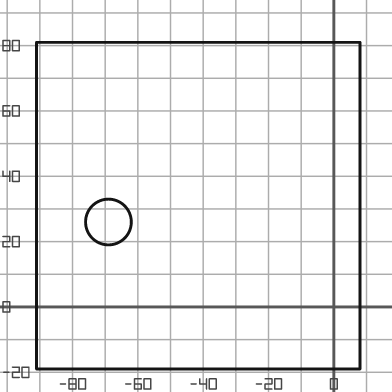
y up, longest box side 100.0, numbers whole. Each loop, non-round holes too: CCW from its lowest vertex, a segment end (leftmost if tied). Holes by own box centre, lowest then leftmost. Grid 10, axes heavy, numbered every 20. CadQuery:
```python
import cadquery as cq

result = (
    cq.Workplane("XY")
    .moveTo(-91.0, -19.0)
    .lineTo(8.0, -19.0)
    .lineTo(8.0, 81.0)
    .lineTo(-91.0, 81.0)
    .close()
    .moveTo(-69.0, 26.0)
    .circle(7.0)
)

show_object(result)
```